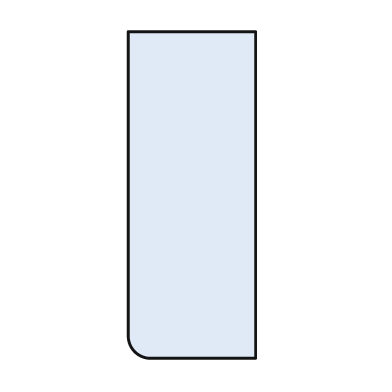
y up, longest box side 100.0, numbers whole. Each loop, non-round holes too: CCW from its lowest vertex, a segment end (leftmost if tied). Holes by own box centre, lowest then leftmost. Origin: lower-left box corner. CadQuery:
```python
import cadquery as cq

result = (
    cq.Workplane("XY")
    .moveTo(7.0, 0.0)
    .lineTo(39.0, 0.0)
    .lineTo(39.0, 100.0)
    .lineTo(0.0, 100.0)
    .lineTo(0.0, 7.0)
    .threePointArc((2.0, 2.0), (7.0, 0.0))
    .close()
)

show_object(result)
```